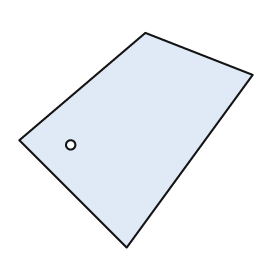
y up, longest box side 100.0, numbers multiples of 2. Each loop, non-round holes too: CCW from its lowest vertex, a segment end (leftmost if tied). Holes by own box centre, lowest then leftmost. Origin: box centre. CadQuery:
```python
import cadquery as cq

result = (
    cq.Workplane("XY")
    .moveTo(-4.0, -46.0)
    .lineTo(50.0, 28.0)
    .lineTo(4.0, 46.0)
    .lineTo(-50.0, 0.0)
    .close()
    .moveTo(-28.0, -2.0)
    .circle(2.0)
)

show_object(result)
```